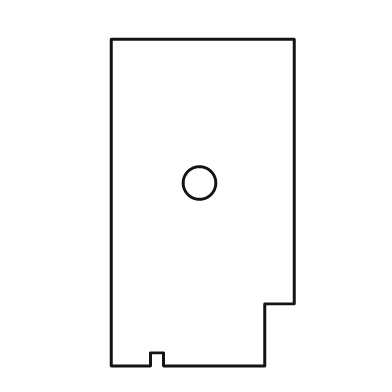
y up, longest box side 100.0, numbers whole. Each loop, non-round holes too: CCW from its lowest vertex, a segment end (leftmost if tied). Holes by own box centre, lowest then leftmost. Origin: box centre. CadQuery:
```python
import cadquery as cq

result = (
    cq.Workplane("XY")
    .moveTo(-28.0, -50.0)
    .lineTo(-16.0, -50.0)
    .lineTo(-16.0, -46.0)
    .lineTo(-12.0, -46.0)
    .lineTo(-12.0, -50.0)
    .lineTo(19.0, -50.0)
    .lineTo(19.0, -31.0)
    .lineTo(28.0, -31.0)
    .lineTo(28.0, 50.0)
    .lineTo(-28.0, 50.0)
    .close()
    .moveTo(-1.0, 6.0)
    .circle(5.0)
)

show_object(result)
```